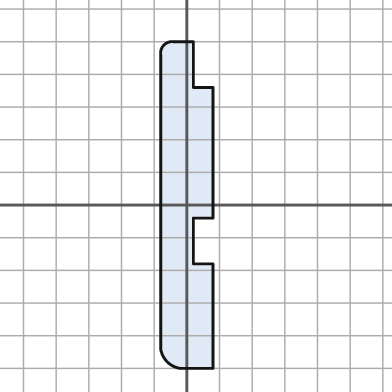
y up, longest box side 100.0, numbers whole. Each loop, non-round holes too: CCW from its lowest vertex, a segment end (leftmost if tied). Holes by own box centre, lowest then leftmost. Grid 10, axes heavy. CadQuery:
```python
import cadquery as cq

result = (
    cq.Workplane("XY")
    .moveTo(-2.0, -50.0)
    .lineTo(8.0, -50.0)
    .lineTo(8.0, -18.0)
    .lineTo(2.0, -18.0)
    .lineTo(2.0, -4.0)
    .lineTo(8.0, -4.0)
    .lineTo(8.0, 36.0)
    .lineTo(2.0, 36.0)
    .lineTo(2.0, 50.0)
    .lineTo(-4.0, 50.0)
    .threePointArc((-7.0, 49.0), (-8.0, 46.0))
    .lineTo(-8.0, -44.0)
    .threePointArc((-6.0, -48.0), (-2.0, -50.0))
    .close()
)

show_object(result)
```